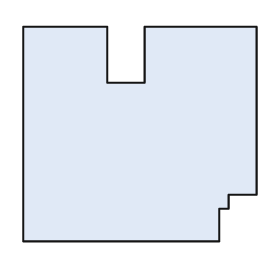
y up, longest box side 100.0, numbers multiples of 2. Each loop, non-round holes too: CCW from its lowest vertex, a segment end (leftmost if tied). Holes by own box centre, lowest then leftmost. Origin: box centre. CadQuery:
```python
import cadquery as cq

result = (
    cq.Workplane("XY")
    .moveTo(-50.0, -46.0)
    .lineTo(34.0, -46.0)
    .lineTo(34.0, -32.0)
    .lineTo(38.0, -32.0)
    .lineTo(38.0, -26.0)
    .lineTo(50.0, -26.0)
    .lineTo(50.0, 46.0)
    .lineTo(2.0, 46.0)
    .lineTo(2.0, 22.0)
    .lineTo(-14.0, 22.0)
    .lineTo(-14.0, 46.0)
    .lineTo(-50.0, 46.0)
    .close()
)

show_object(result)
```